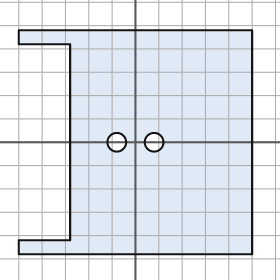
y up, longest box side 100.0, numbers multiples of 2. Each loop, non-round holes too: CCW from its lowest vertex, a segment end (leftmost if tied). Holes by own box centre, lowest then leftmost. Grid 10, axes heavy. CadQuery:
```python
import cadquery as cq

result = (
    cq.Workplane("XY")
    .moveTo(-50.0, -48.0)
    .lineTo(50.0, -48.0)
    .lineTo(50.0, 48.0)
    .lineTo(-50.0, 48.0)
    .lineTo(-50.0, 42.0)
    .lineTo(-28.0, 42.0)
    .lineTo(-28.0, -42.0)
    .lineTo(-50.0, -42.0)
    .close()
    .moveTo(-8.0, 0.0)
    .circle(4.0)
    .moveTo(8.0, 0.0)
    .circle(4.0)
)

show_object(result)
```